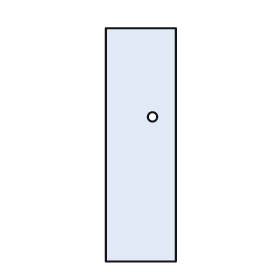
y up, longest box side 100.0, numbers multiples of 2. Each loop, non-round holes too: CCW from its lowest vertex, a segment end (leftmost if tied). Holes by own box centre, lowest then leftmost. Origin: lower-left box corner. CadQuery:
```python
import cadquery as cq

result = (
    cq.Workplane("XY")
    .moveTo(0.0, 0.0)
    .lineTo(30.0, 0.0)
    .lineTo(30.0, 100.0)
    .lineTo(0.0, 100.0)
    .close()
    .moveTo(20.0, 62.0)
    .circle(2.0)
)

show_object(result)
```